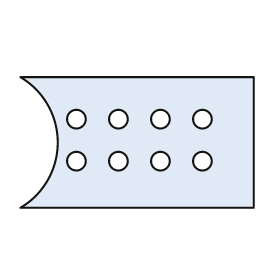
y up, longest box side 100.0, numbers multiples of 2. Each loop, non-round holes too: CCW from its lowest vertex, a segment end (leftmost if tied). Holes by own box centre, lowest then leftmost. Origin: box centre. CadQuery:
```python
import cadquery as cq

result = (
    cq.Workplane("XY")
    .moveTo(-50.0, -28.0)
    .lineTo(50.0, -28.0)
    .lineTo(50.0, 28.0)
    .lineTo(-50.0, 28.0)
    .threePointArc((-34.0, 0.0), (-50.0, -28.0))
    .close()
    .moveTo(-26.0, -8.0)
    .circle(4.0)
    .moveTo(-8.0, -8.0)
    .circle(4.0)
    .moveTo(10.0, -8.0)
    .circle(4.0)
    .moveTo(28.0, -8.0)
    .circle(4.0)
    .moveTo(-26.0, 10.0)
    .circle(4.0)
    .moveTo(-8.0, 10.0)
    .circle(4.0)
    .moveTo(10.0, 10.0)
    .circle(4.0)
    .moveTo(28.0, 10.0)
    .circle(4.0)
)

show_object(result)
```